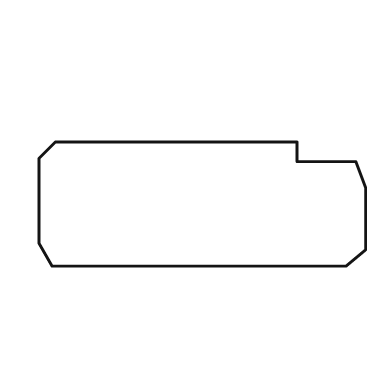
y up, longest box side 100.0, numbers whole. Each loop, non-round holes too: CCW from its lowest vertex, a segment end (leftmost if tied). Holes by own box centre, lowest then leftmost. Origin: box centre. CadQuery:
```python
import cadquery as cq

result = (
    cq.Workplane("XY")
    .moveTo(-46.0, -19.0)
    .lineTo(44.0, -19.0)
    .lineTo(50.0, -14.0)
    .lineTo(50.0, 5.0)
    .lineTo(47.0, 13.0)
    .lineTo(29.0, 13.0)
    .lineTo(29.0, 19.0)
    .lineTo(-45.0, 19.0)
    .lineTo(-50.0, 14.0)
    .lineTo(-50.0, -12.0)
    .close()
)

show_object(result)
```